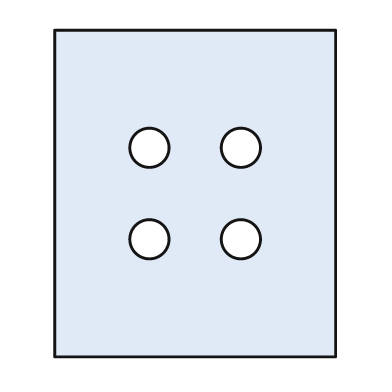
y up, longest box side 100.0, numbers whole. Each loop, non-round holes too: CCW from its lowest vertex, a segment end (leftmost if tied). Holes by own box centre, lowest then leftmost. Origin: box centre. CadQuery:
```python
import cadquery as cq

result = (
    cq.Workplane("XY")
    .moveTo(-43.0, -50.0)
    .lineTo(43.0, -50.0)
    .lineTo(43.0, 50.0)
    .lineTo(-43.0, 50.0)
    .close()
    .moveTo(-14.0, -14.0)
    .circle(6.0)
    .moveTo(14.0, -14.0)
    .circle(6.0)
    .moveTo(-14.0, 14.0)
    .circle(6.0)
    .moveTo(14.0, 14.0)
    .circle(6.0)
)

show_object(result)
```